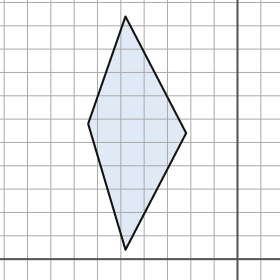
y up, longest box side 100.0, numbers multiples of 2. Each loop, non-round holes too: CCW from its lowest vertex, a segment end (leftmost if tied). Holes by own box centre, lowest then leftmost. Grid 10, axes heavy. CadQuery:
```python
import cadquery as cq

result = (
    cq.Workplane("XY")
    .moveTo(-48.0, 4.0)
    .lineTo(-22.0, 54.0)
    .lineTo(-48.0, 104.0)
    .lineTo(-64.0, 58.0)
    .close()
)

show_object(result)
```